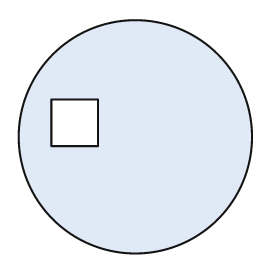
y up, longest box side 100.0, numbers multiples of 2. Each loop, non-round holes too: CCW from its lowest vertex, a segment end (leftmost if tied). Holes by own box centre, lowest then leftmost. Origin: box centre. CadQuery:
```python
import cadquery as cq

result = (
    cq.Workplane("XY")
    .moveTo(0.0, 0.0)
    .circle(50.0)
    .moveTo(-36.0, -4.0)
    .lineTo(-16.0, -4.0)
    .lineTo(-16.0, 16.0)
    .lineTo(-36.0, 16.0)
    .close()
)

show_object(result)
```